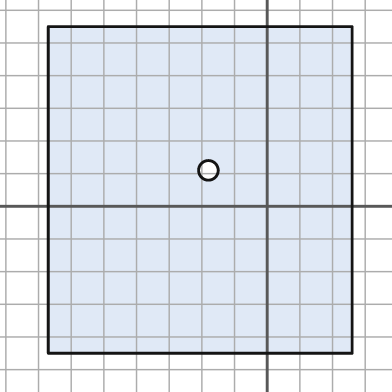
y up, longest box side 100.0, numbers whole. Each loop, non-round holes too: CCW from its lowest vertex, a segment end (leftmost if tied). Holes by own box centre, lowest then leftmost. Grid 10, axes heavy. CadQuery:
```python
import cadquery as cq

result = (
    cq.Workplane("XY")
    .moveTo(-67.0, -45.0)
    .lineTo(26.0, -45.0)
    .lineTo(26.0, 55.0)
    .lineTo(-67.0, 55.0)
    .close()
    .moveTo(-18.0, 11.0)
    .circle(3.0)
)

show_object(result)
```